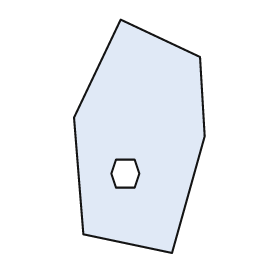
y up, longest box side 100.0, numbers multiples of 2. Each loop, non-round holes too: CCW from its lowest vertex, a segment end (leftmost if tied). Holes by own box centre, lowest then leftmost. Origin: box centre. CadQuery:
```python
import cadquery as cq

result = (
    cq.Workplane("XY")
    .moveTo(14.0, -50.0)
    .lineTo(28.0, 0.0)
    .lineTo(26.0, 34.0)
    .lineTo(-8.0, 50.0)
    .lineTo(-28.0, 8.0)
    .lineTo(-24.0, -42.0)
    .close()
    .moveTo(-10.0, -22.0)
    .lineTo(-2.0, -22.0)
    .lineTo(0.0, -16.0)
    .lineTo(-2.0, -10.0)
    .lineTo(-10.0, -10.0)
    .lineTo(-12.0, -16.0)
    .close()
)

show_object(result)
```